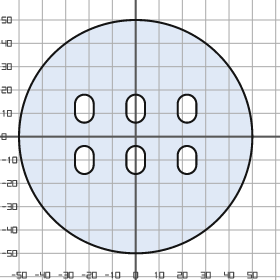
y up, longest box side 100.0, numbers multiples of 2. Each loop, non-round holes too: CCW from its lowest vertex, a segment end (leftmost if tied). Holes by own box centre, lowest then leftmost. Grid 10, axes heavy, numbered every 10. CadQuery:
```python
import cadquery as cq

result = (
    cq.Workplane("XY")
    .moveTo(0.0, 0.0)
    .circle(50.0)
    .moveTo(-26.0, -12.0)
    .threePointArc((-22.0, -16.0), (-18.0, -12.0))
    .lineTo(-18.0, -8.0)
    .threePointArc((-22.0, -4.0), (-26.0, -8.0))
    .close()
    .moveTo(-4.0, -12.0)
    .threePointArc((0.0, -16.0), (4.0, -12.0))
    .lineTo(4.0, -8.0)
    .threePointArc((0.0, -4.0), (-4.0, -8.0))
    .close()
    .moveTo(18.0, -12.0)
    .threePointArc((22.0, -16.0), (26.0, -12.0))
    .lineTo(26.0, -8.0)
    .threePointArc((22.0, -4.0), (18.0, -8.0))
    .close()
    .moveTo(-26.0, 10.0)
    .threePointArc((-22.0, 6.0), (-18.0, 10.0))
    .lineTo(-18.0, 14.0)
    .threePointArc((-22.0, 18.0), (-26.0, 14.0))
    .close()
    .moveTo(-4.0, 10.0)
    .threePointArc((0.0, 6.0), (4.0, 10.0))
    .lineTo(4.0, 14.0)
    .threePointArc((0.0, 18.0), (-4.0, 14.0))
    .close()
    .moveTo(18.0, 10.0)
    .threePointArc((22.0, 6.0), (26.0, 10.0))
    .lineTo(26.0, 14.0)
    .threePointArc((22.0, 18.0), (18.0, 14.0))
    .close()
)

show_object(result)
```